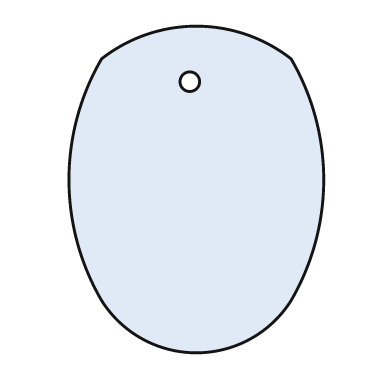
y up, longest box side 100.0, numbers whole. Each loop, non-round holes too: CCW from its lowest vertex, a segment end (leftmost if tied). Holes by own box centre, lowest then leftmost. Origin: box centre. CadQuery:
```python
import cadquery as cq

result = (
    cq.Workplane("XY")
    .moveTo(-29.0, -34.0)
    .threePointArc((0.0, -50.0), (29.0, -34.0))
    .threePointArc((39.0, 3.0), (29.0, 40.0))
    .threePointArc((0.0, 50.0), (-29.0, 40.0))
    .threePointArc((-39.0, 3.0), (-29.0, -34.0))
    .close()
    .moveTo(-2.0, 33.0)
    .circle(3.0)
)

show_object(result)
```